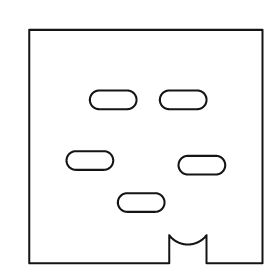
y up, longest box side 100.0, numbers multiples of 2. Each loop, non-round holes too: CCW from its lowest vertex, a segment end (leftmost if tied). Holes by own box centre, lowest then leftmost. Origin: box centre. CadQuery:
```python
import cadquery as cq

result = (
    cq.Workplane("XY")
    .moveTo(-50.0, -50.0)
    .lineTo(10.0, -50.0)
    .lineTo(10.0, -38.0)
    .threePointArc((18.0, -42.0), (26.0, -38.0))
    .lineTo(26.0, -50.0)
    .lineTo(50.0, -50.0)
    .lineTo(50.0, 50.0)
    .lineTo(-50.0, 50.0)
    .close()
    .moveTo(-8.0, -28.0)
    .lineTo(4.0, -28.0)
    .threePointArc((8.0, -24.0), (4.0, -20.0))
    .lineTo(-8.0, -20.0)
    .threePointArc((-12.0, -24.0), (-8.0, -28.0))
    .close()
    .moveTo(18.0, -12.0)
    .lineTo(30.0, -12.0)
    .threePointArc((34.0, -8.0), (30.0, -4.0))
    .lineTo(18.0, -4.0)
    .threePointArc((14.0, -8.0), (18.0, -12.0))
    .close()
    .moveTo(-30.0, -10.0)
    .lineTo(-18.0, -10.0)
    .threePointArc((-14.0, -6.0), (-18.0, -2.0))
    .lineTo(-30.0, -2.0)
    .threePointArc((-34.0, -6.0), (-30.0, -10.0))
    .close()
    .moveTo(-20.0, 16.0)
    .lineTo(-8.0, 16.0)
    .threePointArc((-4.0, 20.0), (-8.0, 24.0))
    .lineTo(-20.0, 24.0)
    .threePointArc((-24.0, 20.0), (-20.0, 16.0))
    .close()
    .moveTo(10.0, 16.0)
    .lineTo(22.0, 16.0)
    .threePointArc((26.0, 20.0), (22.0, 24.0))
    .lineTo(10.0, 24.0)
    .threePointArc((6.0, 20.0), (10.0, 16.0))
    .close()
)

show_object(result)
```